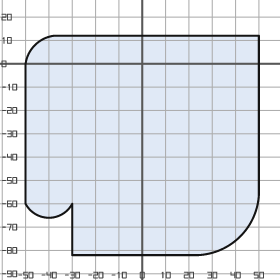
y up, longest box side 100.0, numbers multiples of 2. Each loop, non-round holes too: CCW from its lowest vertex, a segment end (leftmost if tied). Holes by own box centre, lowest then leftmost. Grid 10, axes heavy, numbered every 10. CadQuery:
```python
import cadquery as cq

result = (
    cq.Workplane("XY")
    .moveTo(-30.0, -82.0)
    .lineTo(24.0, -82.0)
    .threePointArc((42.0, -74.0), (50.0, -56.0))
    .lineTo(50.0, 12.0)
    .lineTo(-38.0, 12.0)
    .threePointArc((-46.0, 8.0), (-50.0, 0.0))
    .lineTo(-50.0, -60.0)
    .threePointArc((-40.0, -66.0), (-30.0, -60.0))
    .close()
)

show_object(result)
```